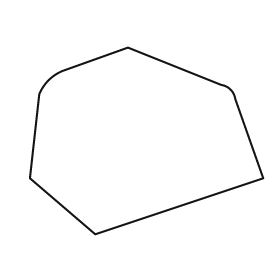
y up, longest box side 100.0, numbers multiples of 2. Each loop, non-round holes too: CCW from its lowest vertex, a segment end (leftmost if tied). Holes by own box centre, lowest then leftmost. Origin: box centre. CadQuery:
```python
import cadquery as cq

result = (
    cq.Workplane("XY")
    .moveTo(-22.0, -40.0)
    .lineTo(50.0, -16.0)
    .lineTo(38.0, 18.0)
    .threePointArc((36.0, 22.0), (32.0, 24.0))
    .lineTo(-8.0, 40.0)
    .lineTo(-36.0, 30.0)
    .threePointArc((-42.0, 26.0), (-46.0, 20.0))
    .lineTo(-50.0, -16.0)
    .close()
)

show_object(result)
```